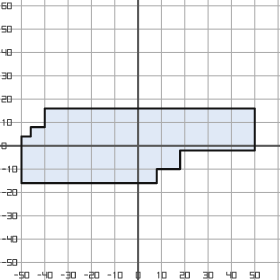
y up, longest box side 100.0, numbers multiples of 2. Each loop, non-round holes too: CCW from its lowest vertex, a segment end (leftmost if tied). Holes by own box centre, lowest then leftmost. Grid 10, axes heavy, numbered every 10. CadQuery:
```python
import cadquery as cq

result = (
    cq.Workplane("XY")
    .moveTo(-50.0, -16.0)
    .lineTo(8.0, -16.0)
    .lineTo(8.0, -10.0)
    .lineTo(18.0, -10.0)
    .lineTo(18.0, -2.0)
    .lineTo(50.0, -2.0)
    .lineTo(50.0, 16.0)
    .lineTo(-40.0, 16.0)
    .lineTo(-40.0, 8.0)
    .lineTo(-46.0, 8.0)
    .lineTo(-46.0, 4.0)
    .lineTo(-50.0, 4.0)
    .close()
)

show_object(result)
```